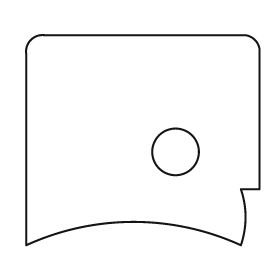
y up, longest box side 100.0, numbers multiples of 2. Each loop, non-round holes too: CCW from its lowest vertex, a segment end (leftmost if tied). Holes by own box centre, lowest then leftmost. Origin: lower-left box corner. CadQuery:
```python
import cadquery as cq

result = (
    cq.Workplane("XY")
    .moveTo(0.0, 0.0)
    .threePointArc((46.0, 10.0), (92.0, 0.0))
    .threePointArc((94.0, 12.0), (92.0, 24.0))
    .lineTo(100.0, 24.0)
    .lineTo(100.0, 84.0)
    .threePointArc((98.0, 88.0), (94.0, 90.0))
    .lineTo(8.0, 90.0)
    .threePointArc((2.0, 88.0), (0.0, 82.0))
    .close()
    .moveTo(64.0, 40.0)
    .circle(10.0)
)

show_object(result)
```